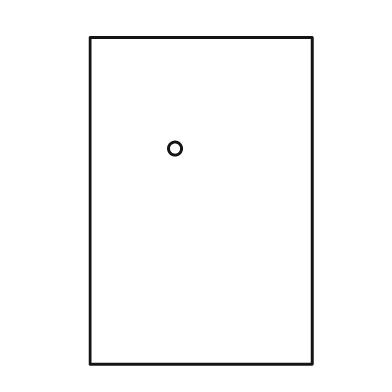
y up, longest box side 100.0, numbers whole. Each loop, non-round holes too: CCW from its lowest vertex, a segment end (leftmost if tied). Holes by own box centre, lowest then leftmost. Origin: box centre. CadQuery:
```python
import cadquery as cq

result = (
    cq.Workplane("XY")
    .moveTo(-34.0, -50.0)
    .lineTo(34.0, -50.0)
    .lineTo(34.0, 50.0)
    .lineTo(-34.0, 50.0)
    .close()
    .moveTo(-8.0, 16.0)
    .circle(2.0)
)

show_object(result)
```